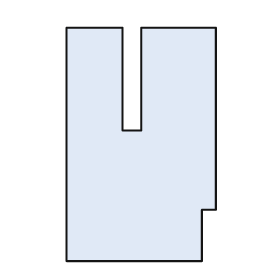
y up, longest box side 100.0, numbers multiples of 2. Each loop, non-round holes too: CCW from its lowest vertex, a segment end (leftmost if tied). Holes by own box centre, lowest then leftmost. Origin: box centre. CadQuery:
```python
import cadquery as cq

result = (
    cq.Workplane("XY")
    .moveTo(-32.0, -50.0)
    .lineTo(26.0, -50.0)
    .lineTo(26.0, -28.0)
    .lineTo(32.0, -28.0)
    .lineTo(32.0, 50.0)
    .lineTo(0.0, 50.0)
    .lineTo(0.0, 6.0)
    .lineTo(-8.0, 6.0)
    .lineTo(-8.0, 50.0)
    .lineTo(-32.0, 50.0)
    .close()
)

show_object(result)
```